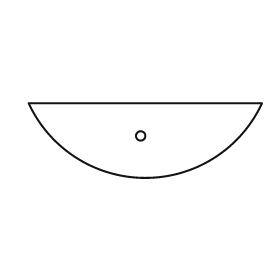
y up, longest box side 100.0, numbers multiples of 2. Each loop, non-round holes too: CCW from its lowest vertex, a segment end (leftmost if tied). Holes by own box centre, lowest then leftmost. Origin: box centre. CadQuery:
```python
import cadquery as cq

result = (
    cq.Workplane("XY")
    .moveTo(-50.0, 16.0)
    .threePointArc((0.0, -16.0), (50.0, 16.0))
    .close()
    .moveTo(-2.0, 2.0)
    .circle(2.0)
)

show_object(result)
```